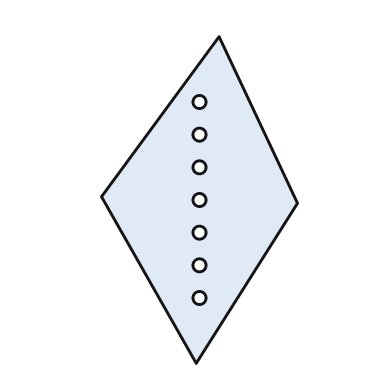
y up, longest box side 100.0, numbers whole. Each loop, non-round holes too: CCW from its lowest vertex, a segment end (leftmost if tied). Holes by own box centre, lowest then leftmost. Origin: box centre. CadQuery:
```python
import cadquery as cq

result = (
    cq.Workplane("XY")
    .moveTo(-1.0, -50.0)
    .lineTo(30.0, -1.0)
    .lineTo(6.0, 50.0)
    .lineTo(-30.0, 1.0)
    .close()
    .moveTo(0.0, -30.0)
    .circle(2.0)
    .moveTo(0.0, -20.0)
    .circle(2.0)
    .moveTo(0.0, -10.0)
    .circle(2.0)
    .moveTo(0.0, 0.0)
    .circle(2.0)
    .moveTo(0.0, 10.0)
    .circle(2.0)
    .moveTo(0.0, 20.0)
    .circle(2.0)
    .moveTo(0.0, 30.0)
    .circle(2.0)
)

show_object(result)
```